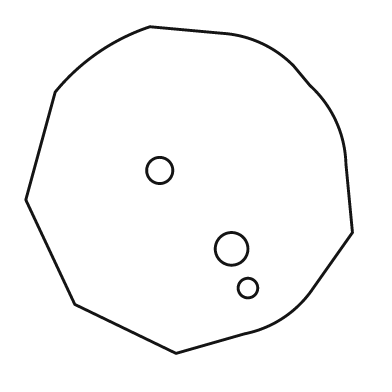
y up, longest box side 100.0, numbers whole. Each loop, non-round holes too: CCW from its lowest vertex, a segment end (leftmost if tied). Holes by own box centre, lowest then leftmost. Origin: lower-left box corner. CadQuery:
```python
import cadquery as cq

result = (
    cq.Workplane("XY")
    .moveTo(46.0, 0.0)
    .lineTo(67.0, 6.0)
    .threePointArc((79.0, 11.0), (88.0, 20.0))
    .lineTo(100.0, 37.0)
    .lineTo(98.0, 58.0)
    .threePointArc((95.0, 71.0), (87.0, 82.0))
    .lineTo(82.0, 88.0)
    .threePointArc((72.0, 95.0), (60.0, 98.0))
    .lineTo(38.0, 100.0)
    .threePointArc((22.0, 92.0), (9.0, 80.0))
    .lineTo(0.0, 47.0)
    .lineTo(15.0, 15.0)
    .close()
    .moveTo(68.0, 20.0)
    .circle(3.0)
    .moveTo(63.0, 32.0)
    .circle(5.0)
    .moveTo(41.0, 56.0)
    .circle(4.0)
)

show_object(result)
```